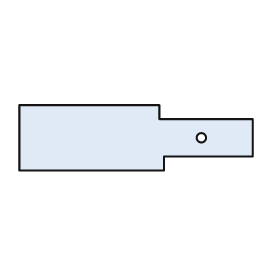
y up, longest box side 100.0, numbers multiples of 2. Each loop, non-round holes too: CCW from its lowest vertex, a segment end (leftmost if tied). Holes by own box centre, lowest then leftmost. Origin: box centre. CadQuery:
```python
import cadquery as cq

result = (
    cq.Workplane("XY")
    .moveTo(-50.0, -14.0)
    .lineTo(12.0, -14.0)
    .lineTo(12.0, -8.0)
    .lineTo(50.0, -8.0)
    .lineTo(50.0, 8.0)
    .lineTo(10.0, 8.0)
    .lineTo(10.0, 14.0)
    .lineTo(-50.0, 14.0)
    .close()
    .moveTo(28.0, 0.0)
    .circle(2.0)
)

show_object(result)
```